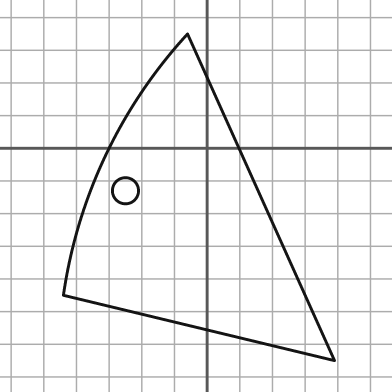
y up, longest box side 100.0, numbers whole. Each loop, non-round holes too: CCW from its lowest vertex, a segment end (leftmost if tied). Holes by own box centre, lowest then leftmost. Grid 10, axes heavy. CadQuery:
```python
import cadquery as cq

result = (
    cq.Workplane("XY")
    .moveTo(39.0, -65.0)
    .lineTo(-6.0, 35.0)
    .threePointArc((-31.0, -2.0), (-44.0, -45.0))
    .close()
    .moveTo(-25.0, -13.0)
    .circle(4.0)
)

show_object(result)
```